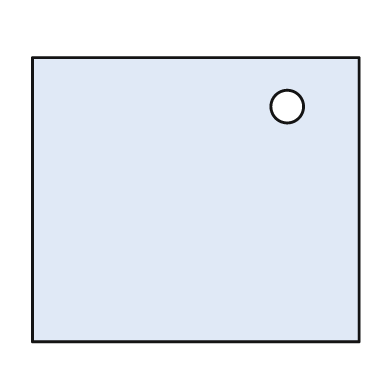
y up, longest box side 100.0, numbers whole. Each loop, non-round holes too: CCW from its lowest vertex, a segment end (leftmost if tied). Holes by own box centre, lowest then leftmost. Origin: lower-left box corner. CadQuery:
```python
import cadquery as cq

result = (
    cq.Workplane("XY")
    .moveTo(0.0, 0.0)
    .lineTo(100.0, 0.0)
    .lineTo(100.0, 87.0)
    .lineTo(0.0, 87.0)
    .close()
    .moveTo(78.0, 72.0)
    .circle(5.0)
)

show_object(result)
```